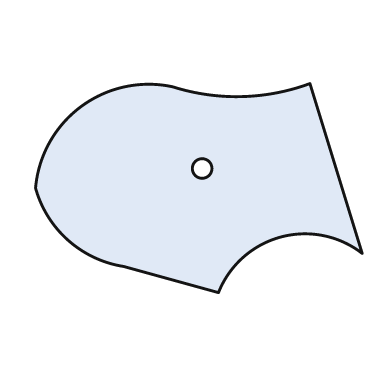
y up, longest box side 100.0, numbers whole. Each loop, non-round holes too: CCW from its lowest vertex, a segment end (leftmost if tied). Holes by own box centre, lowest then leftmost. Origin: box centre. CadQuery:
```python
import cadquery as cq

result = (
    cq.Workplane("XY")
    .moveTo(6.0, -32.0)
    .threePointArc((25.0, -15.0), (50.0, -20.0))
    .lineTo(34.0, 32.0)
    .threePointArc((13.0, 28.0), (-8.0, 31.0))
    .threePointArc((-36.0, 25.0), (-50.0, 0.0))
    .threePointArc((-40.0, -16.0), (-23.0, -24.0))
    .close()
    .moveTo(1.0, 6.0)
    .circle(3.0)
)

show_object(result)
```